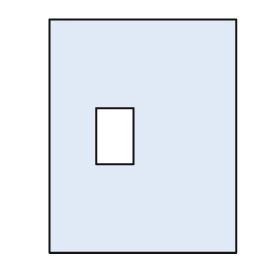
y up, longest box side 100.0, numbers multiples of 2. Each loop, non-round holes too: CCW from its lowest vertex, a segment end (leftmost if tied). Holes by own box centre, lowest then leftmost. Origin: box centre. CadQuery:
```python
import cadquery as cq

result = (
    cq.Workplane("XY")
    .moveTo(-40.0, -50.0)
    .lineTo(40.0, -50.0)
    .lineTo(40.0, 50.0)
    .lineTo(-40.0, 50.0)
    .close()
    .moveTo(-20.0, -12.0)
    .lineTo(-4.0, -12.0)
    .lineTo(-4.0, 12.0)
    .lineTo(-20.0, 12.0)
    .close()
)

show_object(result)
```